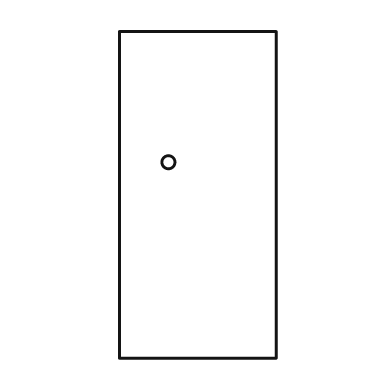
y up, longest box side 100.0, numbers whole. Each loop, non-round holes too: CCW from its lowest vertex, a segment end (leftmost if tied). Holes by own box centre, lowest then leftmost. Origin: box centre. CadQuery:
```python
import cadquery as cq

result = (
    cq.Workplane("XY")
    .moveTo(-24.0, -50.0)
    .lineTo(24.0, -50.0)
    .lineTo(24.0, 50.0)
    .lineTo(-24.0, 50.0)
    .close()
    .moveTo(-9.0, 10.0)
    .circle(2.0)
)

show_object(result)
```